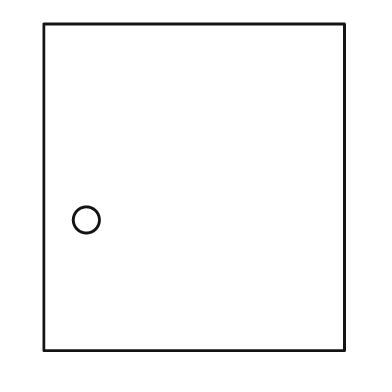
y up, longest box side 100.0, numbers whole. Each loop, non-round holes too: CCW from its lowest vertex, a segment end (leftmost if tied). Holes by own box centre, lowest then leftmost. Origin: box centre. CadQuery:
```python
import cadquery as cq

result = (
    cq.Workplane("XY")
    .moveTo(-46.0, -50.0)
    .lineTo(46.0, -50.0)
    .lineTo(46.0, 50.0)
    .lineTo(-46.0, 50.0)
    .close()
    .moveTo(-33.0, -10.0)
    .circle(4.0)
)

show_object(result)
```